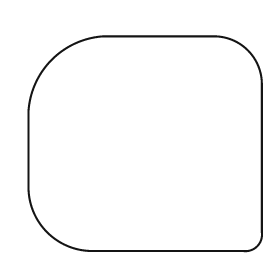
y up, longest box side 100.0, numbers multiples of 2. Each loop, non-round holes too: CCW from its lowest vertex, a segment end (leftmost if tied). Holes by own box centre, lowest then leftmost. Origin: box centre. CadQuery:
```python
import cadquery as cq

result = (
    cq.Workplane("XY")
    .moveTo(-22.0, -46.0)
    .lineTo(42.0, -46.0)
    .threePointArc((48.0, -44.0), (50.0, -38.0))
    .lineTo(50.0, 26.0)
    .threePointArc((44.0, 40.0), (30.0, 46.0))
    .lineTo(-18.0, 46.0)
    .threePointArc((-40.0, 36.0), (-50.0, 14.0))
    .lineTo(-50.0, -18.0)
    .threePointArc((-42.0, -38.0), (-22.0, -46.0))
    .close()
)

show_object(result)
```